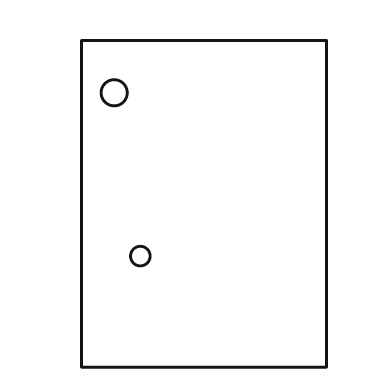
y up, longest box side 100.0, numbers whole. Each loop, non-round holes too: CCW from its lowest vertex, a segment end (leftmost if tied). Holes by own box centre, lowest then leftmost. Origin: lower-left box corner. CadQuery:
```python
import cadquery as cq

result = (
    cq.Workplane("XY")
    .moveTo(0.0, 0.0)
    .lineTo(75.0, 0.0)
    .lineTo(75.0, 100.0)
    .lineTo(0.0, 100.0)
    .close()
    .moveTo(18.0, 34.0)
    .circle(3.0)
    .moveTo(10.0, 84.0)
    .circle(4.0)
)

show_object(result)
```